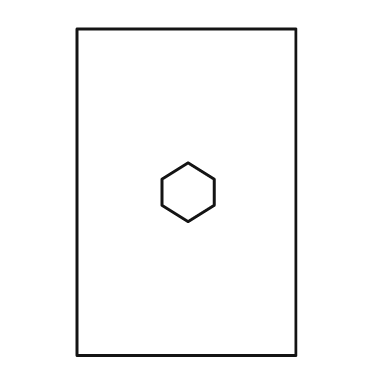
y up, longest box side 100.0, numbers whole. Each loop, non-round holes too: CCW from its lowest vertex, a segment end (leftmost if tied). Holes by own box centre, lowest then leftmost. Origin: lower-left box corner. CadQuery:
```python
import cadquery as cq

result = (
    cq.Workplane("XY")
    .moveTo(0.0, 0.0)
    .lineTo(67.0, 0.0)
    .lineTo(67.0, 100.0)
    .lineTo(0.0, 100.0)
    .close()
    .moveTo(34.0, 41.0)
    .lineTo(42.0, 46.0)
    .lineTo(42.0, 54.0)
    .lineTo(34.0, 59.0)
    .lineTo(26.0, 54.0)
    .lineTo(26.0, 46.0)
    .close()
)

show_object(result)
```